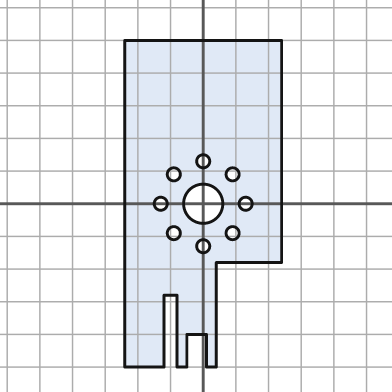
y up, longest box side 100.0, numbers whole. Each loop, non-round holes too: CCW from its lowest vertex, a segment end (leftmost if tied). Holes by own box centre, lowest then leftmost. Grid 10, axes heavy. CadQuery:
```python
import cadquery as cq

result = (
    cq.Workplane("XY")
    .moveTo(-24.0, -50.0)
    .lineTo(-12.0, -50.0)
    .lineTo(-12.0, -28.0)
    .lineTo(-8.0, -28.0)
    .lineTo(-8.0, -50.0)
    .lineTo(-5.0, -50.0)
    .lineTo(-5.0, -40.0)
    .lineTo(1.0, -40.0)
    .lineTo(1.0, -50.0)
    .lineTo(4.0, -50.0)
    .lineTo(4.0, -18.0)
    .lineTo(24.0, -18.0)
    .lineTo(24.0, 50.0)
    .lineTo(-24.0, 50.0)
    .close()
    .moveTo(0.0, -13.0)
    .circle(2.0)
    .moveTo(-9.0, -9.0)
    .circle(2.0)
    .moveTo(9.0, -9.0)
    .circle(2.0)
    .moveTo(-13.0, 0.0)
    .circle(2.0)
    .moveTo(0.0, 0.0)
    .circle(6.0)
    .moveTo(13.0, 0.0)
    .circle(2.0)
    .moveTo(-9.0, 9.0)
    .circle(2.0)
    .moveTo(9.0, 9.0)
    .circle(2.0)
    .moveTo(0.0, 13.0)
    .circle(2.0)
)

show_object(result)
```